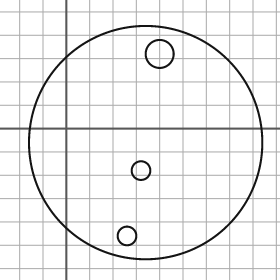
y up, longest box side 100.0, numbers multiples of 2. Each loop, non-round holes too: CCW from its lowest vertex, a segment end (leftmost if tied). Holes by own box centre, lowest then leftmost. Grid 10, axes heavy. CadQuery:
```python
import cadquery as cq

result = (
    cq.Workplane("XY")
    .moveTo(34.0, -6.0)
    .circle(50.0)
    .moveTo(26.0, -46.0)
    .circle(4.0)
    .moveTo(32.0, -18.0)
    .circle(4.0)
    .moveTo(40.0, 32.0)
    .circle(6.0)
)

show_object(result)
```